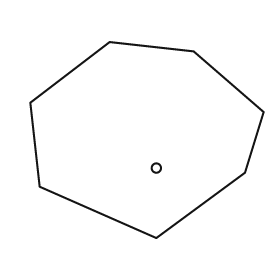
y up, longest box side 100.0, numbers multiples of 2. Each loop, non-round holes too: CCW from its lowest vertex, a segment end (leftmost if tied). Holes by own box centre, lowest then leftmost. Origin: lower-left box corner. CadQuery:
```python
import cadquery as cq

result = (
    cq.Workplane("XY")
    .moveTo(54.0, 0.0)
    .lineTo(92.0, 28.0)
    .lineTo(100.0, 54.0)
    .lineTo(70.0, 80.0)
    .lineTo(34.0, 84.0)
    .lineTo(0.0, 58.0)
    .lineTo(4.0, 22.0)
    .close()
    .moveTo(54.0, 30.0)
    .circle(2.0)
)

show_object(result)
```